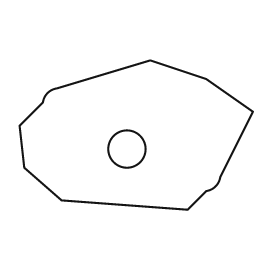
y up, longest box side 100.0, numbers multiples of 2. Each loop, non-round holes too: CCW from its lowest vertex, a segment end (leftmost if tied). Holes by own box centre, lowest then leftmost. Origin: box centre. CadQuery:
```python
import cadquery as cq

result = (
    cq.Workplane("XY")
    .moveTo(22.0, -32.0)
    .lineTo(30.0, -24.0)
    .threePointArc((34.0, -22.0), (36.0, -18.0))
    .lineTo(50.0, 10.0)
    .lineTo(30.0, 24.0)
    .lineTo(6.0, 32.0)
    .lineTo(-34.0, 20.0)
    .threePointArc((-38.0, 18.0), (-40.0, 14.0))
    .lineTo(-50.0, 4.0)
    .lineTo(-48.0, -14.0)
    .lineTo(-32.0, -28.0)
    .close()
    .moveTo(-4.0, -6.0)
    .circle(8.0)
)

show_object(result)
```